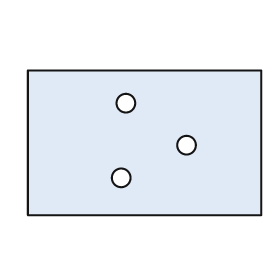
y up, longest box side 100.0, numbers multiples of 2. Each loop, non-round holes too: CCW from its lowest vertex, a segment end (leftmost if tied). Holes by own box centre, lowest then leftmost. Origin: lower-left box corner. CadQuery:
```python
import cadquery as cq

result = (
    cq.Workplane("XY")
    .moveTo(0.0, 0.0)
    .lineTo(100.0, 0.0)
    .lineTo(100.0, 62.0)
    .lineTo(0.0, 62.0)
    .close()
    .moveTo(40.0, 16.0)
    .circle(4.0)
    .moveTo(68.0, 30.0)
    .circle(4.0)
    .moveTo(42.0, 48.0)
    .circle(4.0)
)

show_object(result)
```